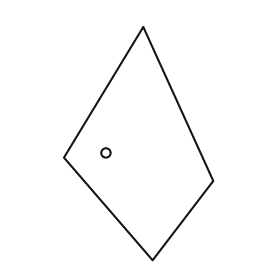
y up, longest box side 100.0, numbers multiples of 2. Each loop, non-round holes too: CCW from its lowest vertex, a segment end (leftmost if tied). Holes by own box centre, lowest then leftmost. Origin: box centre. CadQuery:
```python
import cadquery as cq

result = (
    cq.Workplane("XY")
    .moveTo(6.0, -50.0)
    .lineTo(32.0, -16.0)
    .lineTo(2.0, 50.0)
    .lineTo(-32.0, -6.0)
    .close()
    .moveTo(-14.0, -4.0)
    .circle(2.0)
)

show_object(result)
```